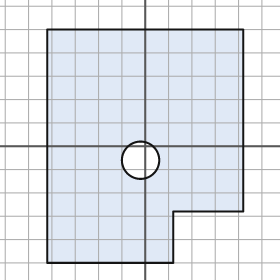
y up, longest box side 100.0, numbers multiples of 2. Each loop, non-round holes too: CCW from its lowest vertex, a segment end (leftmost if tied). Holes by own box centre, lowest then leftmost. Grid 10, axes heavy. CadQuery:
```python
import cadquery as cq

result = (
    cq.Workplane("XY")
    .moveTo(-42.0, -50.0)
    .lineTo(12.0, -50.0)
    .lineTo(12.0, -28.0)
    .lineTo(42.0, -28.0)
    .lineTo(42.0, 50.0)
    .lineTo(-42.0, 50.0)
    .close()
    .moveTo(-2.0, -6.0)
    .circle(8.0)
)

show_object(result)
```